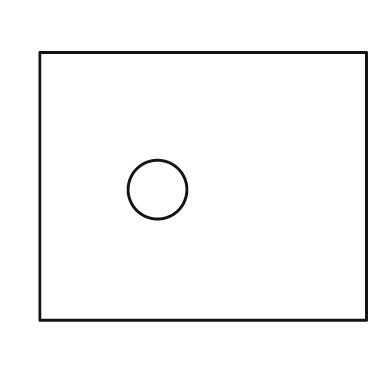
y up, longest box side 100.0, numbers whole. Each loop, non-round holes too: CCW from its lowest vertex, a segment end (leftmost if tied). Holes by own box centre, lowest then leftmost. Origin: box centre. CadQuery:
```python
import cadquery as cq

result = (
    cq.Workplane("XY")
    .moveTo(-50.0, -41.0)
    .lineTo(50.0, -41.0)
    .lineTo(50.0, 41.0)
    .lineTo(-50.0, 41.0)
    .close()
    .moveTo(-14.0, -1.0)
    .circle(9.0)
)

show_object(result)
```